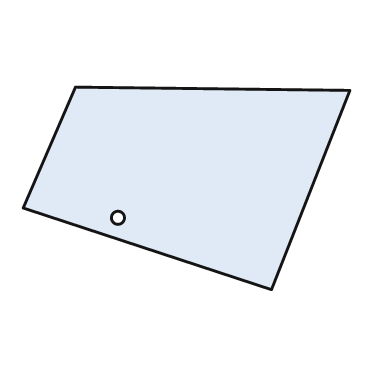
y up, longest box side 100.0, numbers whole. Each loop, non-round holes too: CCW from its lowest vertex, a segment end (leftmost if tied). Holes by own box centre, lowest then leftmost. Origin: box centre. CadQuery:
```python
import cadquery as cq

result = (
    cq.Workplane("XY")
    .moveTo(26.0, -31.0)
    .lineTo(50.0, 30.0)
    .lineTo(-34.0, 31.0)
    .lineTo(-50.0, -6.0)
    .close()
    .moveTo(-21.0, -9.0)
    .circle(2.0)
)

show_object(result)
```